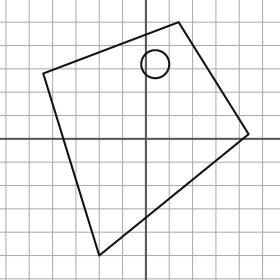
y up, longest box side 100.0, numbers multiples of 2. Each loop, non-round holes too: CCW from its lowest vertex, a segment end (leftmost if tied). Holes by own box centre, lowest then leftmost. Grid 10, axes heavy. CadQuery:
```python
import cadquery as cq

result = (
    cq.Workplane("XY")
    .moveTo(-20.0, -50.0)
    .lineTo(44.0, 2.0)
    .lineTo(14.0, 50.0)
    .lineTo(-44.0, 28.0)
    .close()
    .moveTo(4.0, 32.0)
    .circle(6.0)
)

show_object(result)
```